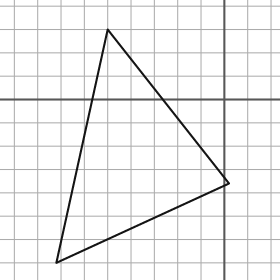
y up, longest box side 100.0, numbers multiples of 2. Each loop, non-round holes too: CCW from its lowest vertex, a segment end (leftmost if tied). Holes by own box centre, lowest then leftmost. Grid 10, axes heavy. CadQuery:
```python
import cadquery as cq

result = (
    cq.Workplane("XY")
    .moveTo(-72.0, -70.0)
    .lineTo(2.0, -36.0)
    .lineTo(-50.0, 30.0)
    .close()
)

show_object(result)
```